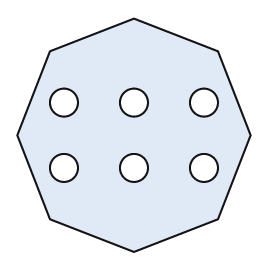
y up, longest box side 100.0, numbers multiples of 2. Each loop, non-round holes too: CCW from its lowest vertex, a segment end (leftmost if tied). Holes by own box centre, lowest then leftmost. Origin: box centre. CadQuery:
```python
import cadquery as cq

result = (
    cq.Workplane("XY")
    .moveTo(0.0, -50.0)
    .lineTo(36.0, -36.0)
    .lineTo(50.0, 0.0)
    .lineTo(36.0, 36.0)
    .lineTo(0.0, 50.0)
    .lineTo(-36.0, 36.0)
    .lineTo(-50.0, 0.0)
    .lineTo(-36.0, -36.0)
    .close()
    .moveTo(-30.0, -14.0)
    .circle(6.0)
    .moveTo(0.0, -14.0)
    .circle(6.0)
    .moveTo(30.0, -14.0)
    .circle(6.0)
    .moveTo(-30.0, 14.0)
    .circle(6.0)
    .moveTo(0.0, 14.0)
    .circle(6.0)
    .moveTo(30.0, 14.0)
    .circle(6.0)
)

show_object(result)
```